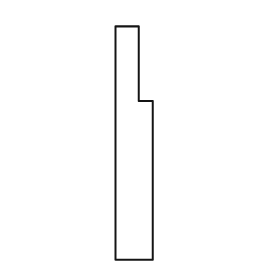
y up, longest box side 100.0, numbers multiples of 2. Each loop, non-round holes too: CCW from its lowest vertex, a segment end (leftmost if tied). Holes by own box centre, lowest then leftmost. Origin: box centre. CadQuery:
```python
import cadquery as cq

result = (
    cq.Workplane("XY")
    .moveTo(-8.0, -50.0)
    .lineTo(8.0, -50.0)
    .lineTo(8.0, 18.0)
    .lineTo(2.0, 18.0)
    .lineTo(2.0, 50.0)
    .lineTo(-8.0, 50.0)
    .close()
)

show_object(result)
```